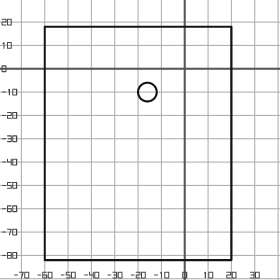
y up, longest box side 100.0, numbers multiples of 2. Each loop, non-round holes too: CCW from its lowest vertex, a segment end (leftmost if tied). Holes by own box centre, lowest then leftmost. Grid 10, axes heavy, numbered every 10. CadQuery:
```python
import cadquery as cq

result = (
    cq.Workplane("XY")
    .moveTo(-60.0, -82.0)
    .lineTo(20.0, -82.0)
    .lineTo(20.0, 18.0)
    .lineTo(-60.0, 18.0)
    .close()
    .moveTo(-16.0, -10.0)
    .circle(4.0)
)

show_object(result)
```